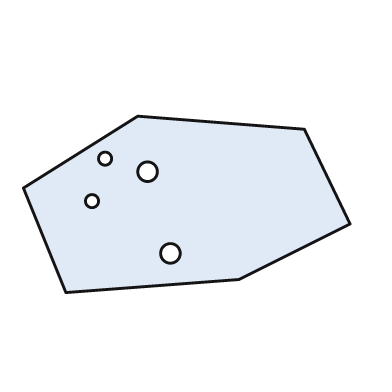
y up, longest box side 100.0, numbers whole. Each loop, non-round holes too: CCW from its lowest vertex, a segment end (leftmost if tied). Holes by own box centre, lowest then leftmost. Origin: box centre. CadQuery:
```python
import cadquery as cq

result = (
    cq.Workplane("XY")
    .moveTo(-37.0, -27.0)
    .lineTo(16.0, -23.0)
    .lineTo(50.0, -6.0)
    .lineTo(36.0, 23.0)
    .lineTo(-15.0, 27.0)
    .lineTo(-50.0, 5.0)
    .close()
    .moveTo(-5.0, -15.0)
    .circle(3.0)
    .moveTo(-29.0, 1.0)
    .circle(2.0)
    .moveTo(-12.0, 10.0)
    .circle(3.0)
    .moveTo(-25.0, 14.0)
    .circle(2.0)
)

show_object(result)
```